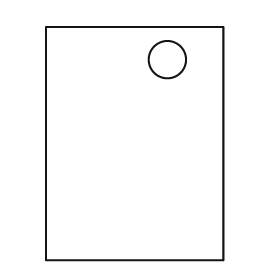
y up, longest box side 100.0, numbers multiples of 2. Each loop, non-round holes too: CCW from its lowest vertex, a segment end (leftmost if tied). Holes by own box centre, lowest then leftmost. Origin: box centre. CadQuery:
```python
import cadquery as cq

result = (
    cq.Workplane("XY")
    .moveTo(-38.0, -50.0)
    .lineTo(38.0, -50.0)
    .lineTo(38.0, 50.0)
    .lineTo(-38.0, 50.0)
    .close()
    .moveTo(14.0, 36.0)
    .circle(8.0)
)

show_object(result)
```